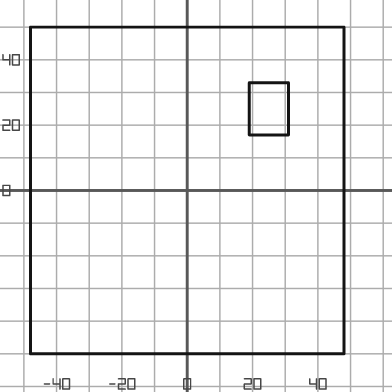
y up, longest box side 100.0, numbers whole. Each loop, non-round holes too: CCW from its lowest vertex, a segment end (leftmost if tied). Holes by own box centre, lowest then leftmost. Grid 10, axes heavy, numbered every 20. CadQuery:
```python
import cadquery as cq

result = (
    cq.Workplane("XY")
    .moveTo(-48.0, -50.0)
    .lineTo(48.0, -50.0)
    .lineTo(48.0, 50.0)
    .lineTo(-48.0, 50.0)
    .close()
    .moveTo(19.0, 17.0)
    .lineTo(31.0, 17.0)
    .lineTo(31.0, 33.0)
    .lineTo(19.0, 33.0)
    .close()
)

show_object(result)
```